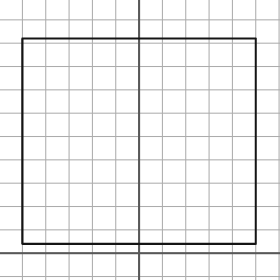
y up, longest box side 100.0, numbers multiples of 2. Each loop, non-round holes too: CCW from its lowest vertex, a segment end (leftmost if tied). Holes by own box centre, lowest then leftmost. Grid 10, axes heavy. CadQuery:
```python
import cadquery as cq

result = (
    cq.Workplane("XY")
    .moveTo(-50.0, 4.0)
    .lineTo(50.0, 4.0)
    .lineTo(50.0, 92.0)
    .lineTo(-50.0, 92.0)
    .close()
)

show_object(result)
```